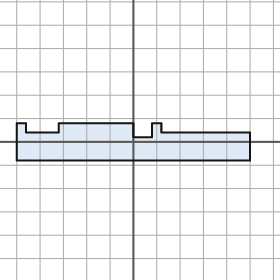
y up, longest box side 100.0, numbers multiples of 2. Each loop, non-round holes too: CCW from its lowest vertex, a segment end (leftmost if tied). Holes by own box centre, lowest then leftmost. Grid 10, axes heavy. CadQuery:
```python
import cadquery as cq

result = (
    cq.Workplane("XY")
    .moveTo(-50.0, -8.0)
    .lineTo(50.0, -8.0)
    .lineTo(50.0, 4.0)
    .lineTo(12.0, 4.0)
    .lineTo(12.0, 8.0)
    .lineTo(8.0, 8.0)
    .lineTo(8.0, 2.0)
    .lineTo(0.0, 2.0)
    .lineTo(0.0, 8.0)
    .lineTo(-32.0, 8.0)
    .lineTo(-32.0, 4.0)
    .lineTo(-46.0, 4.0)
    .lineTo(-46.0, 8.0)
    .lineTo(-50.0, 8.0)
    .close()
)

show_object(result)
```